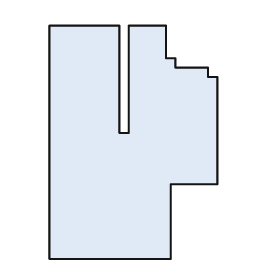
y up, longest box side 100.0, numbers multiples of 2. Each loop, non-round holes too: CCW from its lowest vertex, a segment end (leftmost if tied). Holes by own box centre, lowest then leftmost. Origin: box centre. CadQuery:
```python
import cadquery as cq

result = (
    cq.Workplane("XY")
    .moveTo(-36.0, -50.0)
    .lineTo(16.0, -50.0)
    .lineTo(16.0, -18.0)
    .lineTo(36.0, -18.0)
    .lineTo(36.0, 28.0)
    .lineTo(32.0, 28.0)
    .lineTo(32.0, 32.0)
    .lineTo(18.0, 32.0)
    .lineTo(18.0, 36.0)
    .lineTo(14.0, 36.0)
    .lineTo(14.0, 50.0)
    .lineTo(-2.0, 50.0)
    .lineTo(-2.0, 4.0)
    .lineTo(-6.0, 4.0)
    .lineTo(-6.0, 50.0)
    .lineTo(-36.0, 50.0)
    .close()
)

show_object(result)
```